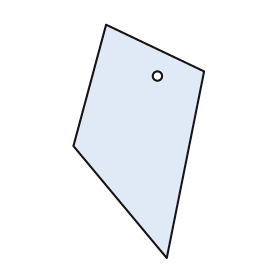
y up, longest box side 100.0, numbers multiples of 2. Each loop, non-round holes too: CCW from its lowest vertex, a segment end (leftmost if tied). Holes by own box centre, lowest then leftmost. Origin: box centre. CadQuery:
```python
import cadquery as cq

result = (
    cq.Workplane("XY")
    .moveTo(12.0, -50.0)
    .lineTo(28.0, 30.0)
    .lineTo(-14.0, 50.0)
    .lineTo(-28.0, -2.0)
    .close()
    .moveTo(8.0, 28.0)
    .circle(2.0)
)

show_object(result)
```